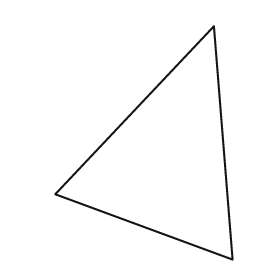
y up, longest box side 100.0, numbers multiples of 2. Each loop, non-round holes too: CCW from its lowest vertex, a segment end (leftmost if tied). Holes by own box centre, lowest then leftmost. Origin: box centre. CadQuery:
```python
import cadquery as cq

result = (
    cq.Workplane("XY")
    .moveTo(38.0, -50.0)
    .lineTo(30.0, 50.0)
    .lineTo(-38.0, -22.0)
    .close()
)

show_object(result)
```